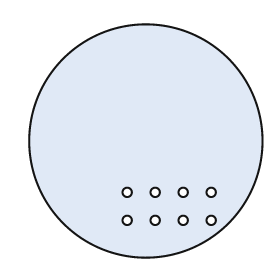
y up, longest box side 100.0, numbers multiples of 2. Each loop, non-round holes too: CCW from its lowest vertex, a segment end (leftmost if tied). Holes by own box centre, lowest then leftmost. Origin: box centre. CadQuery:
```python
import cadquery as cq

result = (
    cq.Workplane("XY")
    .moveTo(0.0, 0.0)
    .circle(50.0)
    .moveTo(-8.0, -34.0)
    .circle(2.0)
    .moveTo(4.0, -34.0)
    .circle(2.0)
    .moveTo(16.0, -34.0)
    .circle(2.0)
    .moveTo(28.0, -34.0)
    .circle(2.0)
    .moveTo(-8.0, -22.0)
    .circle(2.0)
    .moveTo(4.0, -22.0)
    .circle(2.0)
    .moveTo(16.0, -22.0)
    .circle(2.0)
    .moveTo(28.0, -22.0)
    .circle(2.0)
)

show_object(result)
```